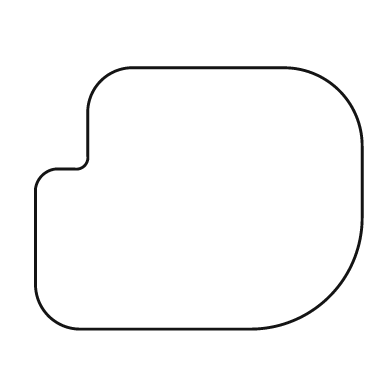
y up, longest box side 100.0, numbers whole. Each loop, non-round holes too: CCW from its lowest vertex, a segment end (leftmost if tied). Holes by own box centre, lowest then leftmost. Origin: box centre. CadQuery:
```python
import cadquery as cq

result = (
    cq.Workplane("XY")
    .moveTo(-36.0, -40.0)
    .lineTo(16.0, -40.0)
    .threePointArc((40.0, -30.0), (50.0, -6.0))
    .lineTo(50.0, 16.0)
    .threePointArc((43.0, 33.0), (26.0, 40.0))
    .lineTo(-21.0, 40.0)
    .threePointArc((-30.0, 36.0), (-34.0, 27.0))
    .lineTo(-34.0, 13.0)
    .threePointArc((-35.0, 10.0), (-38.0, 9.0))
    .lineTo(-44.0, 9.0)
    .threePointArc((-48.0, 7.0), (-50.0, 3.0))
    .lineTo(-50.0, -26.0)
    .threePointArc((-46.0, -36.0), (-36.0, -40.0))
    .close()
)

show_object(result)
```